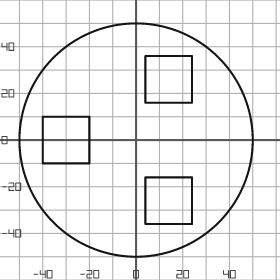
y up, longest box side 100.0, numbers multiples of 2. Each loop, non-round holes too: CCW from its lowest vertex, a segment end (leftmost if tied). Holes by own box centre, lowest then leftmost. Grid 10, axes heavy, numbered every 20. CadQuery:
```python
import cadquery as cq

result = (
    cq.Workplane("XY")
    .moveTo(0.0, 0.0)
    .circle(50.0)
    .moveTo(4.0, -36.0)
    .lineTo(24.0, -36.0)
    .lineTo(24.0, -16.0)
    .lineTo(4.0, -16.0)
    .close()
    .moveTo(-40.0, -10.0)
    .lineTo(-20.0, -10.0)
    .lineTo(-20.0, 10.0)
    .lineTo(-40.0, 10.0)
    .close()
    .moveTo(4.0, 16.0)
    .lineTo(24.0, 16.0)
    .lineTo(24.0, 36.0)
    .lineTo(4.0, 36.0)
    .close()
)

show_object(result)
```